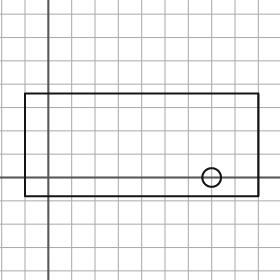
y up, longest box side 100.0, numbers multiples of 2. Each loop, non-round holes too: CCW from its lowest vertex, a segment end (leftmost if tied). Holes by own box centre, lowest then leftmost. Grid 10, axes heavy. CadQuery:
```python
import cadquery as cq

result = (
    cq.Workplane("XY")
    .moveTo(-10.0, -8.0)
    .lineTo(90.0, -8.0)
    .lineTo(90.0, 36.0)
    .lineTo(-10.0, 36.0)
    .close()
    .moveTo(70.0, 0.0)
    .circle(4.0)
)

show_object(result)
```